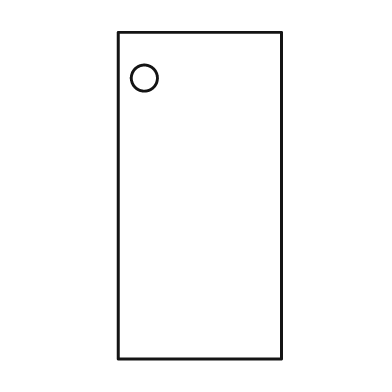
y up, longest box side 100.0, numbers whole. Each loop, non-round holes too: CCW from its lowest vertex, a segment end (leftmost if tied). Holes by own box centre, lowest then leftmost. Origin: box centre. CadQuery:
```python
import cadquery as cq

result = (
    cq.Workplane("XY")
    .moveTo(-25.0, -50.0)
    .lineTo(25.0, -50.0)
    .lineTo(25.0, 50.0)
    .lineTo(-25.0, 50.0)
    .close()
    .moveTo(-17.0, 36.0)
    .circle(4.0)
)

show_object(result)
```